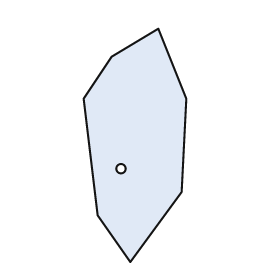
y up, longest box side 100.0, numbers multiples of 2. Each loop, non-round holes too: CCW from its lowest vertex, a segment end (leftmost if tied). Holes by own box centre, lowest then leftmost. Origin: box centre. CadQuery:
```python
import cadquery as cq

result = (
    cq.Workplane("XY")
    .moveTo(-2.0, -50.0)
    .lineTo(20.0, -20.0)
    .lineTo(22.0, 20.0)
    .lineTo(10.0, 50.0)
    .lineTo(-10.0, 38.0)
    .lineTo(-22.0, 20.0)
    .lineTo(-16.0, -30.0)
    .close()
    .moveTo(-6.0, -10.0)
    .circle(2.0)
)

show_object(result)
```